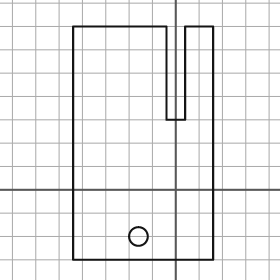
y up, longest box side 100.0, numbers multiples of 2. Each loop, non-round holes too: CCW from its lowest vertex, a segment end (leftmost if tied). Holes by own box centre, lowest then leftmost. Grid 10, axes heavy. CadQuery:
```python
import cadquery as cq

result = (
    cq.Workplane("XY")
    .moveTo(-44.0, -30.0)
    .lineTo(16.0, -30.0)
    .lineTo(16.0, 70.0)
    .lineTo(4.0, 70.0)
    .lineTo(4.0, 30.0)
    .lineTo(-4.0, 30.0)
    .lineTo(-4.0, 70.0)
    .lineTo(-44.0, 70.0)
    .close()
    .moveTo(-16.0, -20.0)
    .circle(4.0)
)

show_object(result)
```